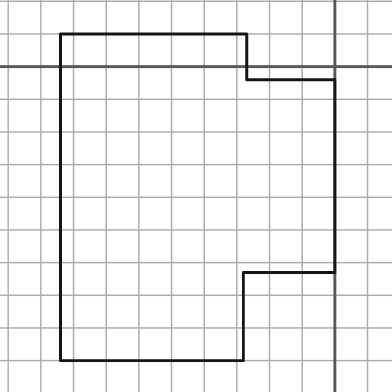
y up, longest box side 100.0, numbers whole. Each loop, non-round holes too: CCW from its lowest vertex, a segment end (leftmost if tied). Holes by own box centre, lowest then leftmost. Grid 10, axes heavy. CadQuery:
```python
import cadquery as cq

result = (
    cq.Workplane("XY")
    .moveTo(-84.0, -90.0)
    .lineTo(-28.0, -90.0)
    .lineTo(-28.0, -63.0)
    .lineTo(0.0, -63.0)
    .lineTo(0.0, -4.0)
    .lineTo(-27.0, -4.0)
    .lineTo(-27.0, 10.0)
    .lineTo(-84.0, 10.0)
    .close()
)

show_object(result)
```